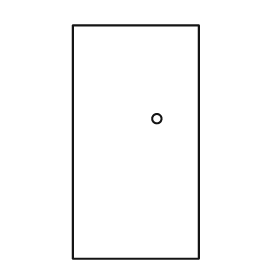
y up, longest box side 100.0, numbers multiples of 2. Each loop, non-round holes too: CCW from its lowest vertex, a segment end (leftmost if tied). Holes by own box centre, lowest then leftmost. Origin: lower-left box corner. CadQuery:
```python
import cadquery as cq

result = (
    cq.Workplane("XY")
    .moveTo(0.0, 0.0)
    .lineTo(54.0, 0.0)
    .lineTo(54.0, 100.0)
    .lineTo(0.0, 100.0)
    .close()
    .moveTo(36.0, 60.0)
    .circle(2.0)
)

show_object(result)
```